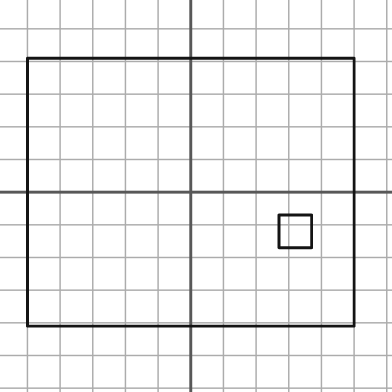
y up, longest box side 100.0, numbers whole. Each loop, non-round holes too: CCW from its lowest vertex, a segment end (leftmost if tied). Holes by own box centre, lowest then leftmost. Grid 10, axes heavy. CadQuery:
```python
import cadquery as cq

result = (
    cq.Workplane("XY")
    .moveTo(-50.0, -41.0)
    .lineTo(50.0, -41.0)
    .lineTo(50.0, 41.0)
    .lineTo(-50.0, 41.0)
    .close()
    .moveTo(27.0, -17.0)
    .lineTo(37.0, -17.0)
    .lineTo(37.0, -7.0)
    .lineTo(27.0, -7.0)
    .close()
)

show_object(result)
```